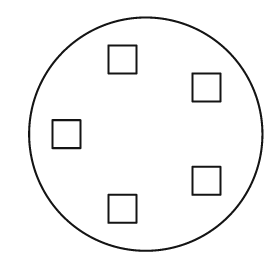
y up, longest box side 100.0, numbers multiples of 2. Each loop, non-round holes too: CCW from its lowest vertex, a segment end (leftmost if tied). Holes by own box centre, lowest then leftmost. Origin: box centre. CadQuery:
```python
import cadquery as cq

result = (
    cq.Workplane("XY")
    .moveTo(0.0, 0.0)
    .circle(50.0)
    .moveTo(-16.0, -38.0)
    .lineTo(-4.0, -38.0)
    .lineTo(-4.0, -26.0)
    .lineTo(-16.0, -26.0)
    .close()
    .moveTo(20.0, -26.0)
    .lineTo(32.0, -26.0)
    .lineTo(32.0, -14.0)
    .lineTo(20.0, -14.0)
    .close()
    .moveTo(-40.0, -6.0)
    .lineTo(-28.0, -6.0)
    .lineTo(-28.0, 6.0)
    .lineTo(-40.0, 6.0)
    .close()
    .moveTo(20.0, 14.0)
    .lineTo(32.0, 14.0)
    .lineTo(32.0, 26.0)
    .lineTo(20.0, 26.0)
    .close()
    .moveTo(-16.0, 26.0)
    .lineTo(-4.0, 26.0)
    .lineTo(-4.0, 38.0)
    .lineTo(-16.0, 38.0)
    .close()
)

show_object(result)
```